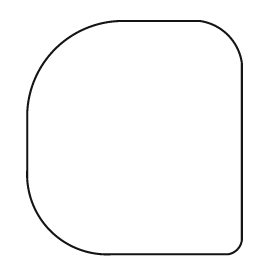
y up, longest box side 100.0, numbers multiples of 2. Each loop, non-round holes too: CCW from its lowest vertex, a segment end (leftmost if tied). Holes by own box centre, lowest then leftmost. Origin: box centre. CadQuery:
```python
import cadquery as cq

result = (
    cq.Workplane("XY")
    .moveTo(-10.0, -50.0)
    .lineTo(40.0, -50.0)
    .threePointArc((44.0, -48.0), (46.0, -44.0))
    .lineTo(46.0, 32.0)
    .threePointArc((40.0, 44.0), (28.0, 50.0))
    .lineTo(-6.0, 50.0)
    .threePointArc((-34.0, 38.0), (-46.0, 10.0))
    .lineTo(-46.0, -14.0)
    .threePointArc((-36.0, -40.0), (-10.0, -50.0))
    .close()
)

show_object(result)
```